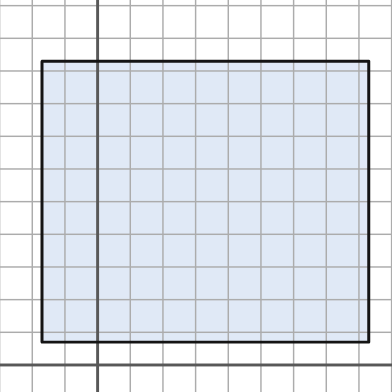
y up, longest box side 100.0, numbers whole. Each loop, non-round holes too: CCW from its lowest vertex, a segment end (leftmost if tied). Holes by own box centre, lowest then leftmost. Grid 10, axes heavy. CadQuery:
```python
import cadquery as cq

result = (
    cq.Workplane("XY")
    .moveTo(-17.0, 7.0)
    .lineTo(83.0, 7.0)
    .lineTo(83.0, 93.0)
    .lineTo(-17.0, 93.0)
    .close()
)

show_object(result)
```